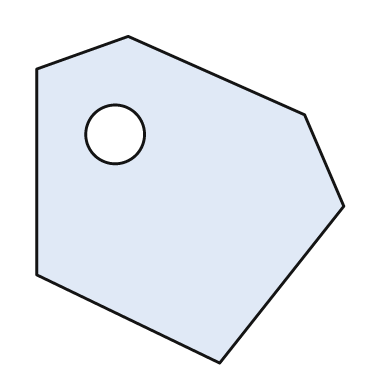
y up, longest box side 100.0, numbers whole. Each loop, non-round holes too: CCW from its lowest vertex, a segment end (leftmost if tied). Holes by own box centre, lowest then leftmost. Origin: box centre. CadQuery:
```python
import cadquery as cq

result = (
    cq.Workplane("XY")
    .moveTo(9.0, -50.0)
    .lineTo(47.0, -2.0)
    .lineTo(35.0, 26.0)
    .lineTo(-19.0, 50.0)
    .lineTo(-47.0, 40.0)
    .lineTo(-47.0, -23.0)
    .close()
    .moveTo(-23.0, 20.0)
    .circle(9.0)
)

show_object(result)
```